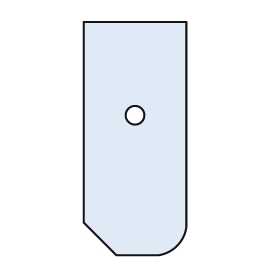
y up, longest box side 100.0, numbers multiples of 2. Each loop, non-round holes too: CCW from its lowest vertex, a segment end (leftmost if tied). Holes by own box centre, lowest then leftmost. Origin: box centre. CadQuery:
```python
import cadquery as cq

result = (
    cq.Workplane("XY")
    .moveTo(-8.0, -50.0)
    .lineTo(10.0, -50.0)
    .threePointArc((18.0, -46.0), (22.0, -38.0))
    .lineTo(22.0, 50.0)
    .lineTo(-22.0, 50.0)
    .lineTo(-22.0, -36.0)
    .close()
    .moveTo(0.0, 10.0)
    .circle(4.0)
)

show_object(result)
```